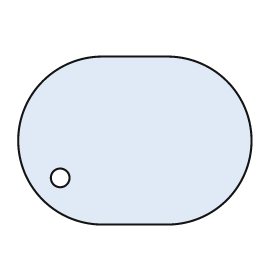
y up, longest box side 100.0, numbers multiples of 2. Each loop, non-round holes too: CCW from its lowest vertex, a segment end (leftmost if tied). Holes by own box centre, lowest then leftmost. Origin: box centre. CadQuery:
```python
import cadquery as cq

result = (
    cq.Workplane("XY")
    .moveTo(-14.0, -36.0)
    .lineTo(14.0, -36.0)
    .threePointArc((50.0, 0.0), (14.0, 36.0))
    .lineTo(-14.0, 36.0)
    .threePointArc((-50.0, 0.0), (-14.0, -36.0))
    .close()
    .moveTo(-32.0, -16.0)
    .circle(4.0)
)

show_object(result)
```